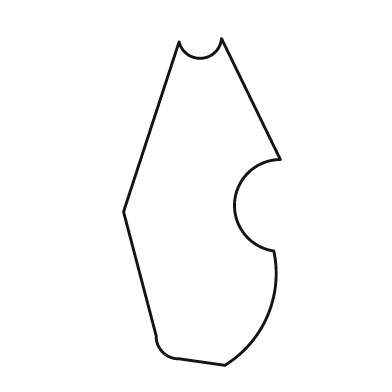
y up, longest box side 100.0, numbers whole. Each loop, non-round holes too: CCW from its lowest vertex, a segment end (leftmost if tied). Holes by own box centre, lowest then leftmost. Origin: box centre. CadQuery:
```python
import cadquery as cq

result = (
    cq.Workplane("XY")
    .moveTo(7.0, -50.0)
    .threePointArc((20.0, -35.0), (22.0, -15.0))
    .threePointArc((10.0, 0.0), (24.0, 13.0))
    .lineTo(6.0, 50.0)
    .threePointArc((0.0, 44.0), (-7.0, 49.0))
    .lineTo(-24.0, -3.0)
    .lineTo(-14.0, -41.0)
    .threePointArc((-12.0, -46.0), (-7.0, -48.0))
    .close()
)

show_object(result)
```